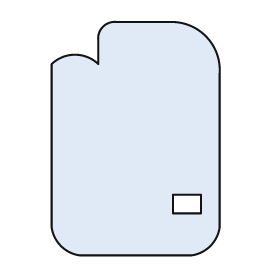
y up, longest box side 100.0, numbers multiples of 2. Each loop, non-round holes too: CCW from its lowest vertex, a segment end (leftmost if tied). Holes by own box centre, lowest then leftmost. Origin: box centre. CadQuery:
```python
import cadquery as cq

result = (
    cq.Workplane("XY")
    .moveTo(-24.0, -50.0)
    .lineTo(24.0, -50.0)
    .threePointArc((32.0, -46.0), (36.0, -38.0))
    .lineTo(36.0, 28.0)
    .threePointArc((30.0, 44.0), (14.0, 50.0))
    .lineTo(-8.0, 50.0)
    .threePointArc((-14.0, 48.0), (-16.0, 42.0))
    .lineTo(-16.0, 32.0)
    .threePointArc((-26.0, 36.0), (-36.0, 32.0))
    .lineTo(-36.0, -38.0)
    .threePointArc((-32.0, -46.0), (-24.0, -50.0))
    .close()
    .moveTo(16.0, -32.0)
    .lineTo(28.0, -32.0)
    .lineTo(28.0, -24.0)
    .lineTo(16.0, -24.0)
    .close()
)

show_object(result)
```